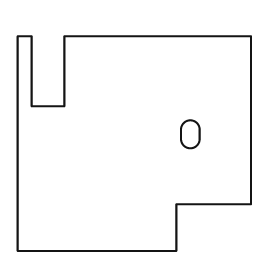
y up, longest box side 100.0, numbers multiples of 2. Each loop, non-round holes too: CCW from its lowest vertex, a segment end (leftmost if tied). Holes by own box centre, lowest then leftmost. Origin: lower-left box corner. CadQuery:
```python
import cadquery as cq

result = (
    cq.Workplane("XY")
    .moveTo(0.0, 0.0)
    .lineTo(68.0, 0.0)
    .lineTo(68.0, 20.0)
    .lineTo(100.0, 20.0)
    .lineTo(100.0, 92.0)
    .lineTo(20.0, 92.0)
    .lineTo(20.0, 62.0)
    .lineTo(6.0, 62.0)
    .lineTo(6.0, 92.0)
    .lineTo(0.0, 92.0)
    .close()
    .moveTo(70.0, 48.0)
    .threePointArc((74.0, 44.0), (78.0, 48.0))
    .lineTo(78.0, 52.0)
    .threePointArc((74.0, 56.0), (70.0, 52.0))
    .close()
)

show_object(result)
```